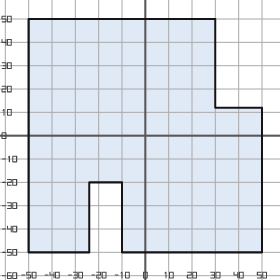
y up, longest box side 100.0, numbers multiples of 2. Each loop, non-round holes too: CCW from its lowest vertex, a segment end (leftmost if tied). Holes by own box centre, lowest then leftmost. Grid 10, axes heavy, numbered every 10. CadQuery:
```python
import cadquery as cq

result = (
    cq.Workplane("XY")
    .moveTo(-50.0, -50.0)
    .lineTo(-24.0, -50.0)
    .lineTo(-24.0, -20.0)
    .lineTo(-10.0, -20.0)
    .lineTo(-10.0, -50.0)
    .lineTo(50.0, -50.0)
    .lineTo(50.0, 12.0)
    .lineTo(30.0, 12.0)
    .lineTo(30.0, 50.0)
    .lineTo(-50.0, 50.0)
    .close()
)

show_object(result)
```